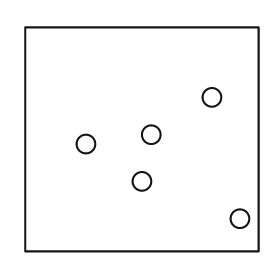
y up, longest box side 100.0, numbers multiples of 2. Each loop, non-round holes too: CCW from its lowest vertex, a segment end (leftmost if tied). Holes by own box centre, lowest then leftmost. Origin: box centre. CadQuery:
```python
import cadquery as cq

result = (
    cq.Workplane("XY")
    .moveTo(-50.0, -48.0)
    .lineTo(50.0, -48.0)
    .lineTo(50.0, 48.0)
    .lineTo(-50.0, 48.0)
    .close()
    .moveTo(42.0, -34.0)
    .circle(4.0)
    .moveTo(0.0, -18.0)
    .circle(4.0)
    .moveTo(-24.0, -2.0)
    .circle(4.0)
    .moveTo(4.0, 2.0)
    .circle(4.0)
    .moveTo(30.0, 18.0)
    .circle(4.0)
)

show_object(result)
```